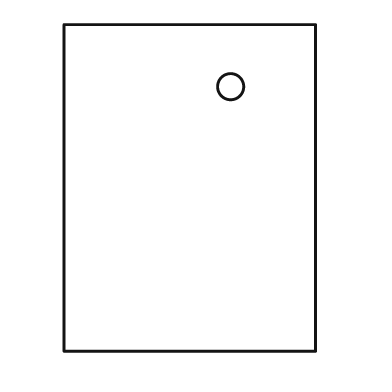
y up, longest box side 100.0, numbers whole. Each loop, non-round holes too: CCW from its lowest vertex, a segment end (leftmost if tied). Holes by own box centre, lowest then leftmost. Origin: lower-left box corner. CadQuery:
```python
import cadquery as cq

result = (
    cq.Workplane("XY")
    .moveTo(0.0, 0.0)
    .lineTo(77.0, 0.0)
    .lineTo(77.0, 100.0)
    .lineTo(0.0, 100.0)
    .close()
    .moveTo(51.0, 81.0)
    .circle(4.0)
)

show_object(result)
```